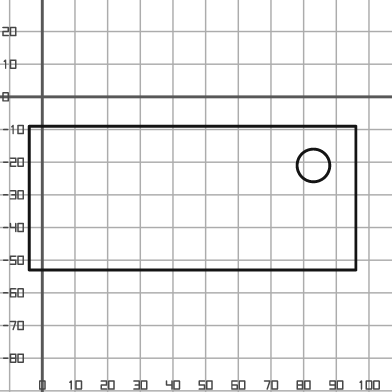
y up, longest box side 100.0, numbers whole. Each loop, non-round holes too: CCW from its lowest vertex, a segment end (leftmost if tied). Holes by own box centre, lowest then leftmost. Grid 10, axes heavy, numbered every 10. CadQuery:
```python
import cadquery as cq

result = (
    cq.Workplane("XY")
    .moveTo(-4.0, -53.0)
    .lineTo(96.0, -53.0)
    .lineTo(96.0, -9.0)
    .lineTo(-4.0, -9.0)
    .close()
    .moveTo(83.0, -21.0)
    .circle(5.0)
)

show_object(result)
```